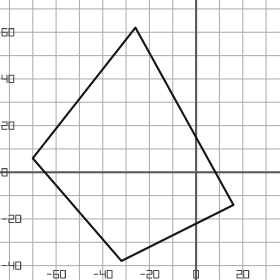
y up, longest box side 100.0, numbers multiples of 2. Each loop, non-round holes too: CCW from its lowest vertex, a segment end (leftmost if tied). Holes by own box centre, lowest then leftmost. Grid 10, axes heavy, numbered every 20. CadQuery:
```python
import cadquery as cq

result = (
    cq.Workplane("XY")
    .moveTo(-32.0, -38.0)
    .lineTo(16.0, -14.0)
    .lineTo(-26.0, 62.0)
    .lineTo(-70.0, 6.0)
    .close()
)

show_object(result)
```